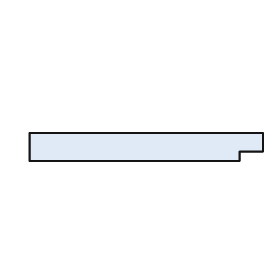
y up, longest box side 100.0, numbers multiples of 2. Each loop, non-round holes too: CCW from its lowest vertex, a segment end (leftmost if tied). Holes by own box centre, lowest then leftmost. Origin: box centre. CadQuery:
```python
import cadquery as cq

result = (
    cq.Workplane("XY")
    .moveTo(-50.0, -6.0)
    .lineTo(40.0, -6.0)
    .lineTo(40.0, -2.0)
    .lineTo(50.0, -2.0)
    .lineTo(50.0, 6.0)
    .lineTo(-50.0, 6.0)
    .close()
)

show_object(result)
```